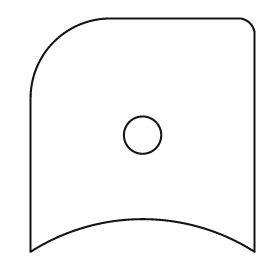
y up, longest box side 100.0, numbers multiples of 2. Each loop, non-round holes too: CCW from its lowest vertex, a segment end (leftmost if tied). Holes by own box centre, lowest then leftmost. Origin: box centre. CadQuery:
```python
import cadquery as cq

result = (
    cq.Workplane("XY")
    .moveTo(-48.0, -50.0)
    .threePointArc((0.0, -36.0), (48.0, -50.0))
    .lineTo(48.0, 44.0)
    .threePointArc((46.0, 48.0), (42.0, 50.0))
    .lineTo(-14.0, 50.0)
    .threePointArc((-38.0, 40.0), (-48.0, 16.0))
    .close()
    .moveTo(0.0, 0.0)
    .circle(8.0)
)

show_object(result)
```